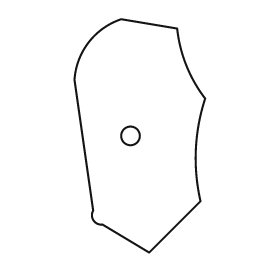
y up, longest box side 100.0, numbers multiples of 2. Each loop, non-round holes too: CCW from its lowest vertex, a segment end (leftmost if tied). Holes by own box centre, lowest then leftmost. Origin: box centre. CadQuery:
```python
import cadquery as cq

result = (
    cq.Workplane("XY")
    .moveTo(4.0, -50.0)
    .lineTo(26.0, -28.0)
    .threePointArc((24.0, -6.0), (28.0, 16.0))
    .threePointArc((20.0, 30.0), (16.0, 46.0))
    .lineTo(-8.0, 50.0)
    .threePointArc((-22.0, 40.0), (-28.0, 24.0))
    .lineTo(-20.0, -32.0)
    .threePointArc((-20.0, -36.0), (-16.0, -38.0))
    .close()
    .moveTo(-4.0, 0.0)
    .circle(4.0)
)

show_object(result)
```